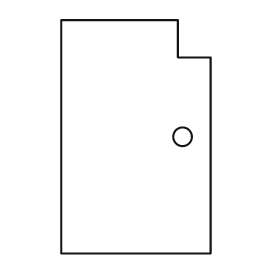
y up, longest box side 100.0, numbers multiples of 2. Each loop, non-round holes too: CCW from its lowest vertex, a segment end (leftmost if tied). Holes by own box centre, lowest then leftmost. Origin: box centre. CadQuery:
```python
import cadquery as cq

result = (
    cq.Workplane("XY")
    .moveTo(-32.0, -50.0)
    .lineTo(32.0, -50.0)
    .lineTo(32.0, 34.0)
    .lineTo(18.0, 34.0)
    .lineTo(18.0, 50.0)
    .lineTo(-32.0, 50.0)
    .close()
    .moveTo(20.0, 0.0)
    .circle(4.0)
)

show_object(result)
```